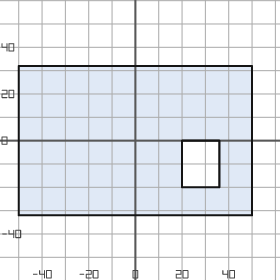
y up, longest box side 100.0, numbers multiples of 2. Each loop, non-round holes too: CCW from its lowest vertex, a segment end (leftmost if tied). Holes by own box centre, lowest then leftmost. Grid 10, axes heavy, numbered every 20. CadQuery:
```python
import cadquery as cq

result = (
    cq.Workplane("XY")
    .moveTo(-50.0, -32.0)
    .lineTo(50.0, -32.0)
    .lineTo(50.0, 32.0)
    .lineTo(-50.0, 32.0)
    .close()
    .moveTo(20.0, -20.0)
    .lineTo(36.0, -20.0)
    .lineTo(36.0, 0.0)
    .lineTo(20.0, 0.0)
    .close()
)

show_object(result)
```